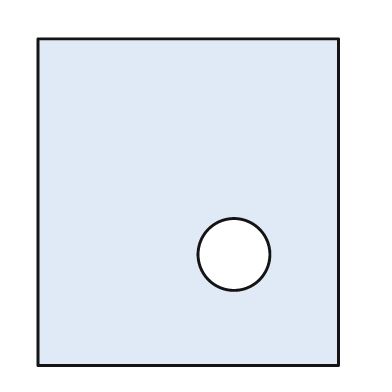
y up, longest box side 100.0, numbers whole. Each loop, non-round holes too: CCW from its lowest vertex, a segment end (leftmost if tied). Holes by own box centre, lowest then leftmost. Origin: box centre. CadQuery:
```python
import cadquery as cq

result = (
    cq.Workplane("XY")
    .moveTo(-46.0, -50.0)
    .lineTo(46.0, -50.0)
    .lineTo(46.0, 50.0)
    .lineTo(-46.0, 50.0)
    .close()
    .moveTo(14.0, -16.0)
    .circle(11.0)
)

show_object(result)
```